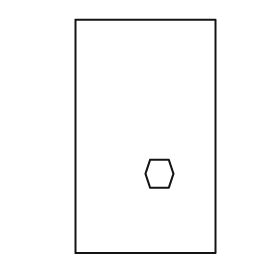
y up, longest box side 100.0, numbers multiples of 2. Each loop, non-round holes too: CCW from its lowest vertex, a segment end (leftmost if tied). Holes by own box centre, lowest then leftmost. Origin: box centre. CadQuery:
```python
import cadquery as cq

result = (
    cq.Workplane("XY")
    .moveTo(-30.0, -50.0)
    .lineTo(30.0, -50.0)
    .lineTo(30.0, 50.0)
    .lineTo(-30.0, 50.0)
    .close()
    .moveTo(2.0, -22.0)
    .lineTo(10.0, -22.0)
    .lineTo(12.0, -16.0)
    .lineTo(10.0, -10.0)
    .lineTo(2.0, -10.0)
    .lineTo(0.0, -16.0)
    .close()
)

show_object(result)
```